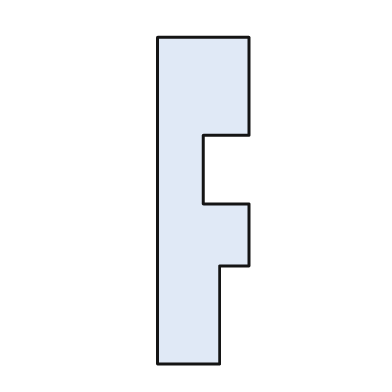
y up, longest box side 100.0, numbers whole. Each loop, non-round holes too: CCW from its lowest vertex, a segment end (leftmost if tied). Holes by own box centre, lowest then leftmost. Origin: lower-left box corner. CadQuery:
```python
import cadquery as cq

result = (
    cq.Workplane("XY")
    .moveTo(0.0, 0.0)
    .lineTo(19.0, 0.0)
    .lineTo(19.0, 30.0)
    .lineTo(28.0, 30.0)
    .lineTo(28.0, 49.0)
    .lineTo(14.0, 49.0)
    .lineTo(14.0, 70.0)
    .lineTo(28.0, 70.0)
    .lineTo(28.0, 100.0)
    .lineTo(0.0, 100.0)
    .close()
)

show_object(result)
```